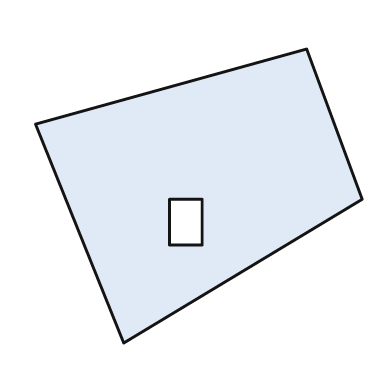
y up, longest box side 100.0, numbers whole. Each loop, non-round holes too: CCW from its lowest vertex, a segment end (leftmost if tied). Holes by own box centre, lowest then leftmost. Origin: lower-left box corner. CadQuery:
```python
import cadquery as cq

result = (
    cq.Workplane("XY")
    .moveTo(27.0, 0.0)
    .lineTo(100.0, 44.0)
    .lineTo(83.0, 90.0)
    .lineTo(0.0, 67.0)
    .close()
    .moveTo(41.0, 30.0)
    .lineTo(51.0, 30.0)
    .lineTo(51.0, 44.0)
    .lineTo(41.0, 44.0)
    .close()
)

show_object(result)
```